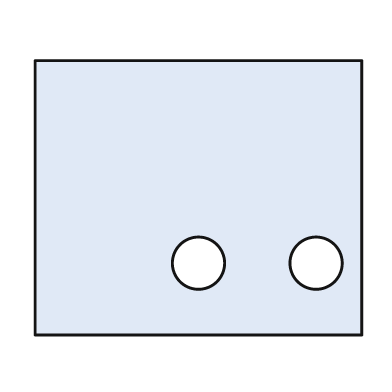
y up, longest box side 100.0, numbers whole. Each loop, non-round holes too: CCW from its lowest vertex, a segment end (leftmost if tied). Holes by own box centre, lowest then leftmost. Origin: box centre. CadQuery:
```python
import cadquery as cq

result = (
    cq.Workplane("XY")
    .moveTo(-50.0, -42.0)
    .lineTo(50.0, -42.0)
    .lineTo(50.0, 42.0)
    .lineTo(-50.0, 42.0)
    .close()
    .moveTo(0.0, -20.0)
    .circle(8.0)
    .moveTo(36.0, -20.0)
    .circle(8.0)
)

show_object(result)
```